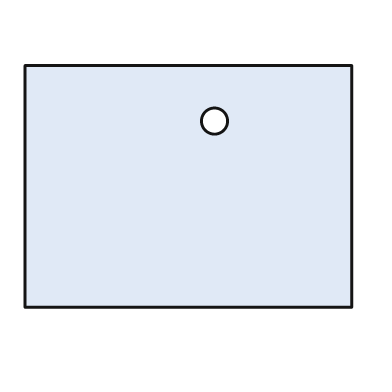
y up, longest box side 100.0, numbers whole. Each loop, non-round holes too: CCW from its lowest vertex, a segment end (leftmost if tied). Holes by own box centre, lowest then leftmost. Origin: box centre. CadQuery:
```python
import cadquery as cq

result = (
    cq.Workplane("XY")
    .moveTo(-50.0, -37.0)
    .lineTo(50.0, -37.0)
    .lineTo(50.0, 37.0)
    .lineTo(-50.0, 37.0)
    .close()
    .moveTo(8.0, 20.0)
    .circle(4.0)
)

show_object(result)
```